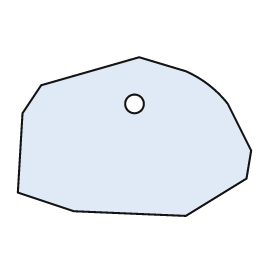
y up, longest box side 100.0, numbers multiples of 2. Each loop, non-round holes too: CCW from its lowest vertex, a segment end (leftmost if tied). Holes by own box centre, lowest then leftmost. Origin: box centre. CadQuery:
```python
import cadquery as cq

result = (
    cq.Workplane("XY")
    .moveTo(22.0, -34.0)
    .lineTo(48.0, -18.0)
    .lineTo(50.0, -6.0)
    .lineTo(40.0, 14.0)
    .threePointArc((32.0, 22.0), (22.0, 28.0))
    .lineTo(2.0, 34.0)
    .lineTo(-40.0, 22.0)
    .lineTo(-48.0, 10.0)
    .lineTo(-50.0, -24.0)
    .lineTo(-26.0, -32.0)
    .close()
    .moveTo(0.0, 14.0)
    .circle(4.0)
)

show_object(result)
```